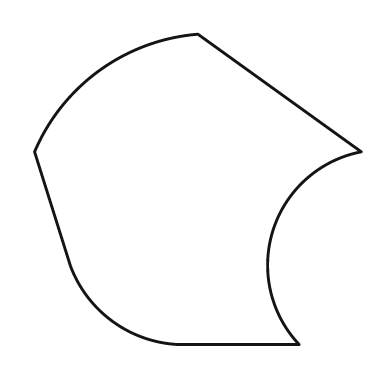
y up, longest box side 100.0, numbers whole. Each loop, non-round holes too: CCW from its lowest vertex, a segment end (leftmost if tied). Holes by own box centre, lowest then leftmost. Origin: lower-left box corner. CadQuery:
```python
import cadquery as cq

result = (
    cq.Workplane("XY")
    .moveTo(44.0, 0.0)
    .lineTo(81.0, 0.0)
    .threePointArc((73.0, 35.0), (100.0, 59.0))
    .lineTo(50.0, 95.0)
    .threePointArc((20.0, 84.0), (0.0, 59.0))
    .lineTo(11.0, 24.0)
    .threePointArc((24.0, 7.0), (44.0, 0.0))
    .close()
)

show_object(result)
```